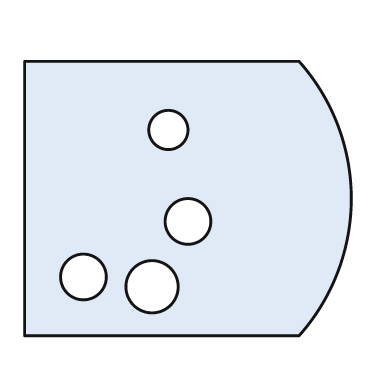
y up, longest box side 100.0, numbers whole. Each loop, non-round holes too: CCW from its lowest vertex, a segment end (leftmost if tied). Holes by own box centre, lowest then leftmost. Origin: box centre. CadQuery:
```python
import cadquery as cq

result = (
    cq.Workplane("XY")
    .moveTo(-50.0, -42.0)
    .lineTo(34.0, -42.0)
    .threePointArc((50.0, 0.0), (34.0, 42.0))
    .lineTo(-50.0, 42.0)
    .close()
    .moveTo(-11.0, -27.0)
    .circle(8.0)
    .moveTo(-32.0, -24.0)
    .circle(7.0)
    .moveTo(0.0, -7.0)
    .circle(7.0)
    .moveTo(-6.0, 21.0)
    .circle(6.0)
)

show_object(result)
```